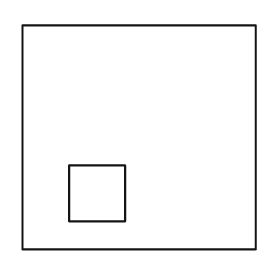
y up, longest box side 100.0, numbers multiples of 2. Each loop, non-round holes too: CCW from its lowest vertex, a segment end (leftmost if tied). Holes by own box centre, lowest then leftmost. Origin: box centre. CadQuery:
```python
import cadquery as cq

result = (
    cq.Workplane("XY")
    .moveTo(-50.0, -48.0)
    .lineTo(50.0, -48.0)
    .lineTo(50.0, 48.0)
    .lineTo(-50.0, 48.0)
    .close()
    .moveTo(-30.0, -36.0)
    .lineTo(-6.0, -36.0)
    .lineTo(-6.0, -12.0)
    .lineTo(-30.0, -12.0)
    .close()
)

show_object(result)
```